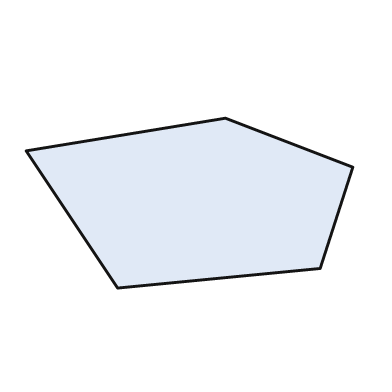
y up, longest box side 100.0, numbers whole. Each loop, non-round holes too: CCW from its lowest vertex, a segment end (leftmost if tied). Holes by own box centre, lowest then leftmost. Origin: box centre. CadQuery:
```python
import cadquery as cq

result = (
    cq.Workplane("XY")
    .moveTo(-22.0, -26.0)
    .lineTo(40.0, -20.0)
    .lineTo(50.0, 11.0)
    .lineTo(11.0, 26.0)
    .lineTo(-50.0, 16.0)
    .close()
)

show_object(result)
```